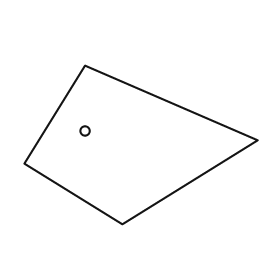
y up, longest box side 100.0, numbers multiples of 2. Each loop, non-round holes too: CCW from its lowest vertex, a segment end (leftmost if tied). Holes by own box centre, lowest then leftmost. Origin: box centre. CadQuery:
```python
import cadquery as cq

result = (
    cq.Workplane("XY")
    .moveTo(-8.0, -34.0)
    .lineTo(50.0, 2.0)
    .lineTo(-24.0, 34.0)
    .lineTo(-50.0, -8.0)
    .close()
    .moveTo(-24.0, 6.0)
    .circle(2.0)
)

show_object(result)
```